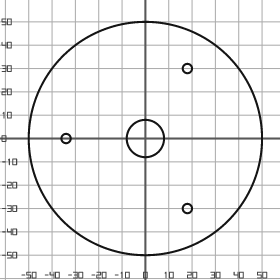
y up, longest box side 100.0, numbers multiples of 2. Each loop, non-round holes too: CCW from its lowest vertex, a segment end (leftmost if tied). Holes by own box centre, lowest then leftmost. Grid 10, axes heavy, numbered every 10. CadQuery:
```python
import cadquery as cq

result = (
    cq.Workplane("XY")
    .moveTo(0.0, 0.0)
    .circle(50.0)
    .moveTo(18.0, -30.0)
    .circle(2.0)
    .moveTo(-34.0, 0.0)
    .circle(2.0)
    .moveTo(0.0, 0.0)
    .circle(8.0)
    .moveTo(18.0, 30.0)
    .circle(2.0)
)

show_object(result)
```